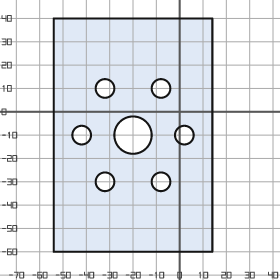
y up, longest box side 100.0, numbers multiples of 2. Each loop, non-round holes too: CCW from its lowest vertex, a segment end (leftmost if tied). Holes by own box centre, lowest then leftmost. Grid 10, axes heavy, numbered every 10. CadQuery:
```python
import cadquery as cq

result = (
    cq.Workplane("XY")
    .moveTo(-54.0, -60.0)
    .lineTo(14.0, -60.0)
    .lineTo(14.0, 40.0)
    .lineTo(-54.0, 40.0)
    .close()
    .moveTo(-32.0, -30.0)
    .circle(4.0)
    .moveTo(-8.0, -30.0)
    .circle(4.0)
    .moveTo(-42.0, -10.0)
    .circle(4.0)
    .moveTo(-20.0, -10.0)
    .circle(8.0)
    .moveTo(2.0, -10.0)
    .circle(4.0)
    .moveTo(-32.0, 10.0)
    .circle(4.0)
    .moveTo(-8.0, 10.0)
    .circle(4.0)
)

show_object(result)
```